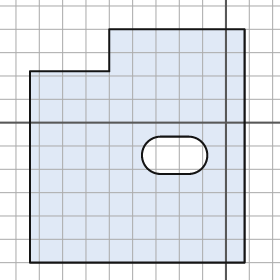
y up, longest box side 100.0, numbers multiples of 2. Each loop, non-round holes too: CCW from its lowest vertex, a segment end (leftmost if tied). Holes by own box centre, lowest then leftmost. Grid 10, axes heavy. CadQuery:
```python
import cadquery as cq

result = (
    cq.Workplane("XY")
    .moveTo(-84.0, -60.0)
    .lineTo(8.0, -60.0)
    .lineTo(8.0, 40.0)
    .lineTo(-50.0, 40.0)
    .lineTo(-50.0, 22.0)
    .lineTo(-84.0, 22.0)
    .close()
    .moveTo(-28.0, -22.0)
    .lineTo(-16.0, -22.0)
    .threePointArc((-8.0, -14.0), (-16.0, -6.0))
    .lineTo(-28.0, -6.0)
    .threePointArc((-36.0, -14.0), (-28.0, -22.0))
    .close()
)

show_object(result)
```